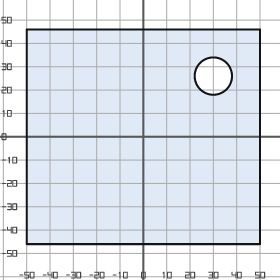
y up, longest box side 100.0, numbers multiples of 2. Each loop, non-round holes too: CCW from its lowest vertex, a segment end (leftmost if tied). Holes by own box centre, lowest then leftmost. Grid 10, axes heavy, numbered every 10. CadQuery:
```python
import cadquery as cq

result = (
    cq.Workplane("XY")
    .moveTo(-50.0, -46.0)
    .lineTo(50.0, -46.0)
    .lineTo(50.0, 46.0)
    .lineTo(-50.0, 46.0)
    .close()
    .moveTo(30.0, 26.0)
    .circle(8.0)
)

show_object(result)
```